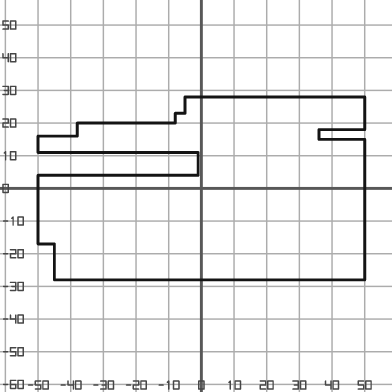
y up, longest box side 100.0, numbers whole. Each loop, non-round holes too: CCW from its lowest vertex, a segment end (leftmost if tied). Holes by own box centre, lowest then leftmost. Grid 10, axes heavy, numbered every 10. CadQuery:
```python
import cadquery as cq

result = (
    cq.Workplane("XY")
    .moveTo(-45.0, -28.0)
    .lineTo(50.0, -28.0)
    .lineTo(50.0, 15.0)
    .lineTo(36.0, 15.0)
    .lineTo(36.0, 18.0)
    .lineTo(50.0, 18.0)
    .lineTo(50.0, 28.0)
    .lineTo(-5.0, 28.0)
    .lineTo(-5.0, 23.0)
    .lineTo(-8.0, 23.0)
    .lineTo(-8.0, 20.0)
    .lineTo(-38.0, 20.0)
    .lineTo(-38.0, 16.0)
    .lineTo(-50.0, 16.0)
    .lineTo(-50.0, 11.0)
    .lineTo(-1.0, 11.0)
    .lineTo(-1.0, 4.0)
    .lineTo(-50.0, 4.0)
    .lineTo(-50.0, -17.0)
    .lineTo(-45.0, -17.0)
    .close()
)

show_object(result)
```